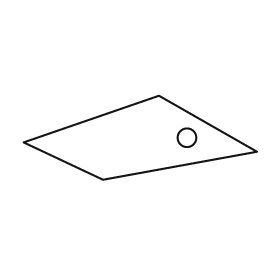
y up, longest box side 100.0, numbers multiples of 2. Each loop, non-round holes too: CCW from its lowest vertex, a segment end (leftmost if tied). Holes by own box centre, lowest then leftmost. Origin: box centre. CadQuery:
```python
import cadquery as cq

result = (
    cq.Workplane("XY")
    .moveTo(-16.0, -18.0)
    .lineTo(50.0, -6.0)
    .lineTo(8.0, 18.0)
    .lineTo(-50.0, -2.0)
    .close()
    .moveTo(20.0, 0.0)
    .circle(4.0)
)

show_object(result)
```